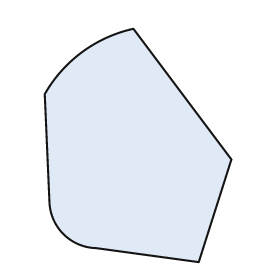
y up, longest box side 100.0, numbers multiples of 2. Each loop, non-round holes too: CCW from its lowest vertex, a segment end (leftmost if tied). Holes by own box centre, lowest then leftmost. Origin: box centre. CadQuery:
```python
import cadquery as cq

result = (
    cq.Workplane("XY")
    .moveTo(26.0, -50.0)
    .lineTo(40.0, -6.0)
    .lineTo(-2.0, 50.0)
    .threePointArc((-24.0, 40.0), (-40.0, 22.0))
    .lineTo(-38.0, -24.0)
    .threePointArc((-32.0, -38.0), (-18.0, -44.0))
    .close()
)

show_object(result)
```